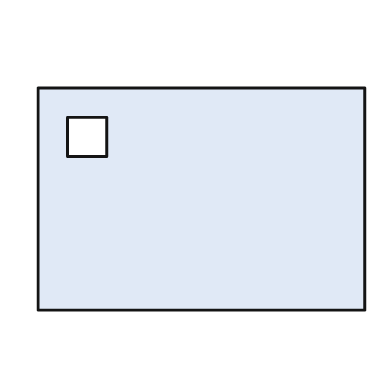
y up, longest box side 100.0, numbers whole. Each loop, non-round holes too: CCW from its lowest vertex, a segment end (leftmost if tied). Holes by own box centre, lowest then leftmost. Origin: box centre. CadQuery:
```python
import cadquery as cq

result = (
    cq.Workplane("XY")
    .moveTo(-50.0, -34.0)
    .lineTo(50.0, -34.0)
    .lineTo(50.0, 34.0)
    .lineTo(-50.0, 34.0)
    .close()
    .moveTo(-41.0, 13.0)
    .lineTo(-29.0, 13.0)
    .lineTo(-29.0, 25.0)
    .lineTo(-41.0, 25.0)
    .close()
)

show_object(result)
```